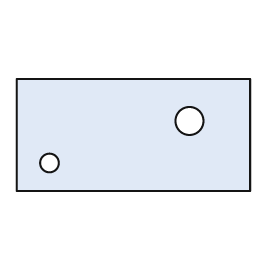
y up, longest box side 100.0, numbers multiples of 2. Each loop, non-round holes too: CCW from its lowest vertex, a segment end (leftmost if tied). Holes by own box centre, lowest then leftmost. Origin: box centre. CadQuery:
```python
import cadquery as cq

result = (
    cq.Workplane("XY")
    .moveTo(-50.0, -24.0)
    .lineTo(50.0, -24.0)
    .lineTo(50.0, 24.0)
    .lineTo(-50.0, 24.0)
    .close()
    .moveTo(-36.0, -12.0)
    .circle(4.0)
    .moveTo(24.0, 6.0)
    .circle(6.0)
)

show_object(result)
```